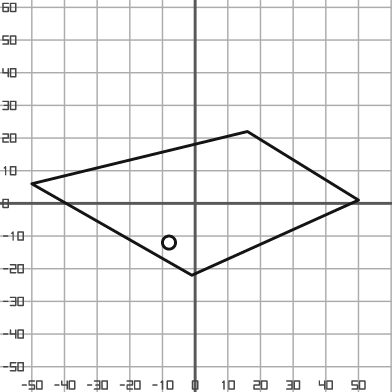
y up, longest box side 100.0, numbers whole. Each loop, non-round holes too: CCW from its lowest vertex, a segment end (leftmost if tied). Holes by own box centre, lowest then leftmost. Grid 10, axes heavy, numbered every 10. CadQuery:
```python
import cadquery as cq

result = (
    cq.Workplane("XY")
    .moveTo(-1.0, -22.0)
    .lineTo(50.0, 1.0)
    .lineTo(16.0, 22.0)
    .lineTo(-50.0, 6.0)
    .close()
    .moveTo(-8.0, -12.0)
    .circle(2.0)
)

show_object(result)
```